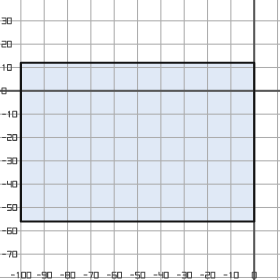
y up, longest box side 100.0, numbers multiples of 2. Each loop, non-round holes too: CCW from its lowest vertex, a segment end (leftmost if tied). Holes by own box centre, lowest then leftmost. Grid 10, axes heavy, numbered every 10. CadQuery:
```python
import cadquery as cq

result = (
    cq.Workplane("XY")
    .moveTo(-100.0, -56.0)
    .lineTo(0.0, -56.0)
    .lineTo(0.0, 12.0)
    .lineTo(-100.0, 12.0)
    .close()
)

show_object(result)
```